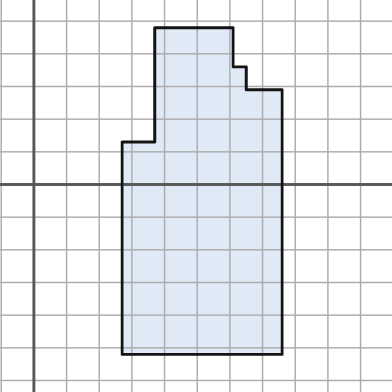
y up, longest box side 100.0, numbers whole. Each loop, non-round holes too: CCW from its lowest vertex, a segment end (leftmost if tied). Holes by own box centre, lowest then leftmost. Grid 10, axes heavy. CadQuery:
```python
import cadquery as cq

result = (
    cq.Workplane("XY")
    .moveTo(27.0, -52.0)
    .lineTo(76.0, -52.0)
    .lineTo(76.0, 29.0)
    .lineTo(65.0, 29.0)
    .lineTo(65.0, 36.0)
    .lineTo(61.0, 36.0)
    .lineTo(61.0, 48.0)
    .lineTo(37.0, 48.0)
    .lineTo(37.0, 13.0)
    .lineTo(27.0, 13.0)
    .close()
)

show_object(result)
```